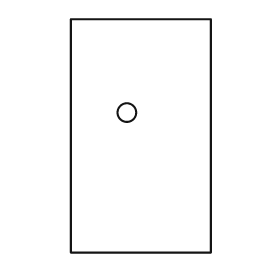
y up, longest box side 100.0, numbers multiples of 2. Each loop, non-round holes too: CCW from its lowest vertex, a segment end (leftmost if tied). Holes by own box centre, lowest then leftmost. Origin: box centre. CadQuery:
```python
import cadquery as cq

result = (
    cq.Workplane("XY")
    .moveTo(-30.0, -50.0)
    .lineTo(30.0, -50.0)
    .lineTo(30.0, 50.0)
    .lineTo(-30.0, 50.0)
    .close()
    .moveTo(-6.0, 10.0)
    .circle(4.0)
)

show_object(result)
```